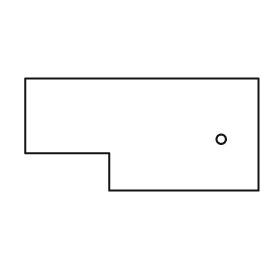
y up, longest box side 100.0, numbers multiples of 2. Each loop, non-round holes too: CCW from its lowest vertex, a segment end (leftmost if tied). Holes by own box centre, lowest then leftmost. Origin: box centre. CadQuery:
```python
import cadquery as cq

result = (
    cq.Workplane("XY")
    .moveTo(-14.0, -24.0)
    .lineTo(50.0, -24.0)
    .lineTo(50.0, 24.0)
    .lineTo(-50.0, 24.0)
    .lineTo(-50.0, -8.0)
    .lineTo(-14.0, -8.0)
    .close()
    .moveTo(34.0, -2.0)
    .circle(2.0)
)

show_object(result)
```